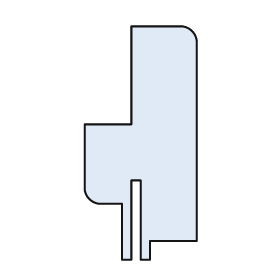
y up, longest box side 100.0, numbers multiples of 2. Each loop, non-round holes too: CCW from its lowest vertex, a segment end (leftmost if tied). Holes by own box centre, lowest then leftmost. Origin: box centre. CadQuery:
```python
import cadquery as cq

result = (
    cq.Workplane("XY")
    .moveTo(-8.0, -50.0)
    .lineTo(-4.0, -50.0)
    .lineTo(-4.0, -16.0)
    .lineTo(0.0, -16.0)
    .lineTo(0.0, -50.0)
    .lineTo(4.0, -50.0)
    .lineTo(4.0, -42.0)
    .lineTo(24.0, -42.0)
    .lineTo(24.0, 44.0)
    .threePointArc((22.0, 48.0), (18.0, 50.0))
    .lineTo(-4.0, 50.0)
    .lineTo(-4.0, 8.0)
    .lineTo(-24.0, 8.0)
    .lineTo(-24.0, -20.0)
    .threePointArc((-22.0, -24.0), (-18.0, -26.0))
    .lineTo(-8.0, -26.0)
    .close()
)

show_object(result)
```